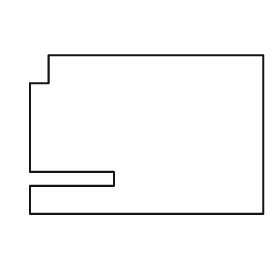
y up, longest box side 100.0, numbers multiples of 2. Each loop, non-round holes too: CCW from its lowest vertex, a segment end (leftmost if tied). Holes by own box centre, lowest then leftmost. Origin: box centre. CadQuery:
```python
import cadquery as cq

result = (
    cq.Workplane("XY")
    .moveTo(-50.0, -34.0)
    .lineTo(50.0, -34.0)
    .lineTo(50.0, 34.0)
    .lineTo(-42.0, 34.0)
    .lineTo(-42.0, 22.0)
    .lineTo(-50.0, 22.0)
    .lineTo(-50.0, -16.0)
    .lineTo(-14.0, -16.0)
    .lineTo(-14.0, -22.0)
    .lineTo(-50.0, -22.0)
    .close()
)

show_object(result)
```